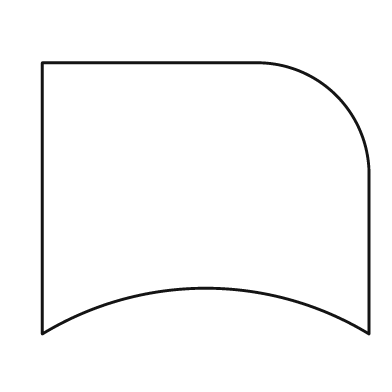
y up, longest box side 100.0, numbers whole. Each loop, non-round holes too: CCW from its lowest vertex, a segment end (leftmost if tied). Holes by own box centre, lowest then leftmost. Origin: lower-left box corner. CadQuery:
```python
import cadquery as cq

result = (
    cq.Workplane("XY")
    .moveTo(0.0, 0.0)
    .threePointArc((50.0, 14.0), (100.0, 0.0))
    .lineTo(100.0, 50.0)
    .threePointArc((90.0, 73.0), (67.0, 83.0))
    .lineTo(0.0, 83.0)
    .close()
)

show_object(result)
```